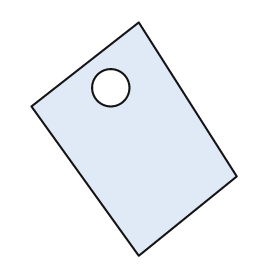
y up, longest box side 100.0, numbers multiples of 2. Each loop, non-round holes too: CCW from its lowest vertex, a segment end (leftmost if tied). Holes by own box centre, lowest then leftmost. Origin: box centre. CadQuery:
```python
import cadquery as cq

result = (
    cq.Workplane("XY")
    .moveTo(2.0, -50.0)
    .lineTo(44.0, -16.0)
    .lineTo(2.0, 50.0)
    .lineTo(-44.0, 14.0)
    .close()
    .moveTo(-10.0, 22.0)
    .circle(8.0)
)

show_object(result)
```